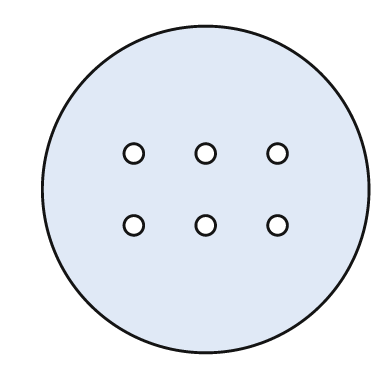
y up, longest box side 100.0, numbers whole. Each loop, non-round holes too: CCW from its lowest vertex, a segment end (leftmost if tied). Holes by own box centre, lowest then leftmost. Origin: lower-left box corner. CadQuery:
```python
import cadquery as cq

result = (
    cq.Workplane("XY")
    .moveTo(50.0, 50.0)
    .circle(50.0)
    .moveTo(28.0, 39.0)
    .circle(3.0)
    .moveTo(50.0, 39.0)
    .circle(3.0)
    .moveTo(72.0, 39.0)
    .circle(3.0)
    .moveTo(28.0, 61.0)
    .circle(3.0)
    .moveTo(50.0, 61.0)
    .circle(3.0)
    .moveTo(72.0, 61.0)
    .circle(3.0)
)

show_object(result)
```